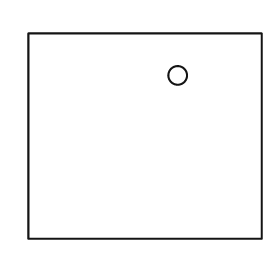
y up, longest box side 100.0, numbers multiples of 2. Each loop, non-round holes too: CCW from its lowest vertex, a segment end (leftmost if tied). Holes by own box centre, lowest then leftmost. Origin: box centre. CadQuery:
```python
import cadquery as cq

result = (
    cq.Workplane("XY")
    .moveTo(-50.0, -44.0)
    .lineTo(50.0, -44.0)
    .lineTo(50.0, 44.0)
    .lineTo(-50.0, 44.0)
    .close()
    .moveTo(14.0, 26.0)
    .circle(4.0)
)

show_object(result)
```